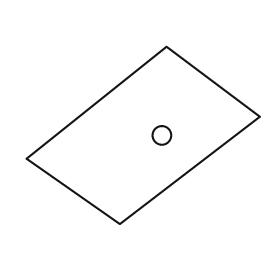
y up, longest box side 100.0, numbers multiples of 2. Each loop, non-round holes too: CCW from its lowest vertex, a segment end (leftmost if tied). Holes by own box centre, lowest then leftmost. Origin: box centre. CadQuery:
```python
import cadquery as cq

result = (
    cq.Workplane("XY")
    .moveTo(-10.0, -38.0)
    .lineTo(50.0, 8.0)
    .lineTo(10.0, 38.0)
    .lineTo(-50.0, -10.0)
    .close()
    .moveTo(8.0, 0.0)
    .circle(4.0)
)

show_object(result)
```